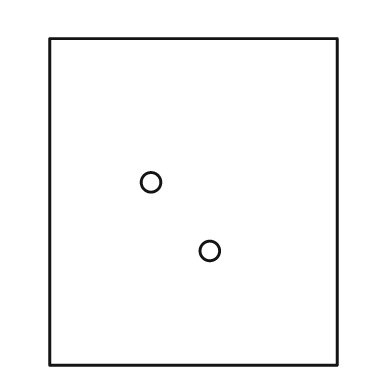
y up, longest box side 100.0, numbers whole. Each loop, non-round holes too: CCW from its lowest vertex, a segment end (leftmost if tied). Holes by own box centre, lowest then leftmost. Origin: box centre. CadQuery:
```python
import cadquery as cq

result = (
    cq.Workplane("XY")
    .moveTo(-44.0, -50.0)
    .lineTo(44.0, -50.0)
    .lineTo(44.0, 50.0)
    .lineTo(-44.0, 50.0)
    .close()
    .moveTo(5.0, -15.0)
    .circle(3.0)
    .moveTo(-13.0, 6.0)
    .circle(3.0)
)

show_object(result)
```